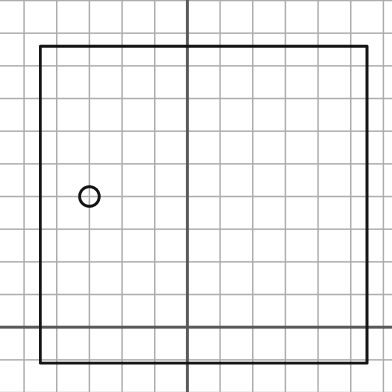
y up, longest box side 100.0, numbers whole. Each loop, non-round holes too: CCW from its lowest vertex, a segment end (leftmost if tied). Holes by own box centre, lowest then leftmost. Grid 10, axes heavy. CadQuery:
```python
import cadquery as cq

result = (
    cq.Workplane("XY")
    .moveTo(-45.0, -11.0)
    .lineTo(55.0, -11.0)
    .lineTo(55.0, 86.0)
    .lineTo(-45.0, 86.0)
    .close()
    .moveTo(-30.0, 40.0)
    .circle(3.0)
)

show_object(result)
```